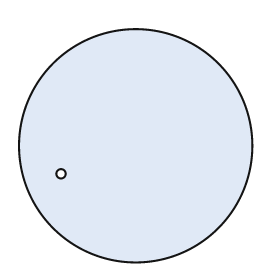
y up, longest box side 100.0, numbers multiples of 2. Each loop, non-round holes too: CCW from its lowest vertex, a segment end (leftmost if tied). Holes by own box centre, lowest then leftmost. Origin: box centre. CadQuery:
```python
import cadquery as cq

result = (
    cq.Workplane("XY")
    .moveTo(0.0, 0.0)
    .circle(50.0)
    .moveTo(-32.0, -12.0)
    .circle(2.0)
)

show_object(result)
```